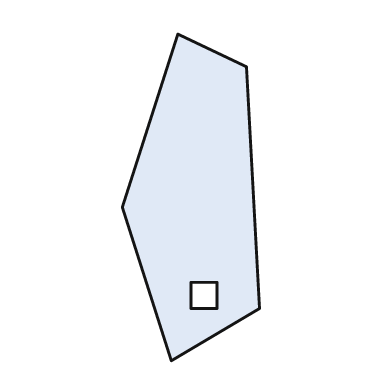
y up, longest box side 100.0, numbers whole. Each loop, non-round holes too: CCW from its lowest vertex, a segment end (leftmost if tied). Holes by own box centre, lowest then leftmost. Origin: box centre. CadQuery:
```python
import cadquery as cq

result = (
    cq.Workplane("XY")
    .moveTo(-6.0, -50.0)
    .lineTo(21.0, -34.0)
    .lineTo(17.0, 40.0)
    .lineTo(-4.0, 50.0)
    .lineTo(-21.0, -3.0)
    .close()
    .moveTo(0.0, -34.0)
    .lineTo(8.0, -34.0)
    .lineTo(8.0, -26.0)
    .lineTo(0.0, -26.0)
    .close()
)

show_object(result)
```